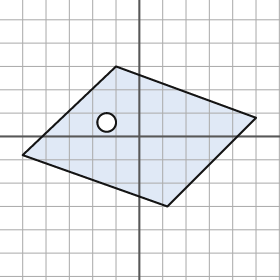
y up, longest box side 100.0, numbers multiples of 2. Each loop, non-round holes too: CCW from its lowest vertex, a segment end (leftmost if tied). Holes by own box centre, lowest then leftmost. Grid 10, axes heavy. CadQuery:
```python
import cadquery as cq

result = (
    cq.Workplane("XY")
    .moveTo(12.0, -30.0)
    .lineTo(50.0, 8.0)
    .lineTo(-10.0, 30.0)
    .lineTo(-50.0, -8.0)
    .close()
    .moveTo(-14.0, 6.0)
    .circle(4.0)
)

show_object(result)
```